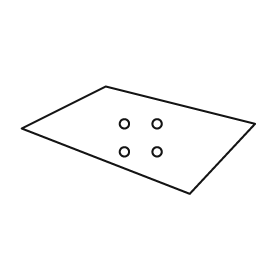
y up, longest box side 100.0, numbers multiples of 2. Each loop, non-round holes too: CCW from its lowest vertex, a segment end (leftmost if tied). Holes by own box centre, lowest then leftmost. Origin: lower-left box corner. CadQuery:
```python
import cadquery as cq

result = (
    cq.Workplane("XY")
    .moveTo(72.0, 0.0)
    .lineTo(100.0, 30.0)
    .lineTo(36.0, 46.0)
    .lineTo(0.0, 28.0)
    .close()
    .moveTo(44.0, 18.0)
    .circle(2.0)
    .moveTo(58.0, 18.0)
    .circle(2.0)
    .moveTo(44.0, 30.0)
    .circle(2.0)
    .moveTo(58.0, 30.0)
    .circle(2.0)
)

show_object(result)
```